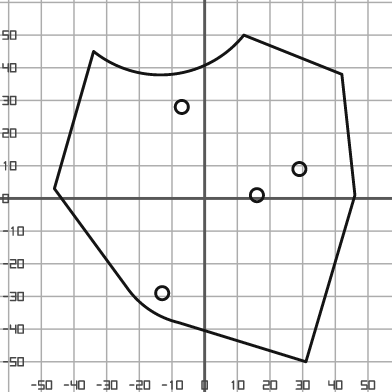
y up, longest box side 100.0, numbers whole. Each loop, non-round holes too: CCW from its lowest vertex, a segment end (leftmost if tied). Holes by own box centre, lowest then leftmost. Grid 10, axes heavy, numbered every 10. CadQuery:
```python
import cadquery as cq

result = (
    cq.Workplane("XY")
    .moveTo(31.0, -50.0)
    .lineTo(46.0, 1.0)
    .lineTo(42.0, 38.0)
    .lineTo(12.0, 50.0)
    .threePointArc((-10.0, 38.0), (-34.0, 45.0))
    .lineTo(-46.0, 3.0)
    .lineTo(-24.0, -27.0)
    .threePointArc((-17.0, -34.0), (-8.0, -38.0))
    .close()
    .moveTo(-13.0, -29.0)
    .circle(2.0)
    .moveTo(16.0, 1.0)
    .circle(2.0)
    .moveTo(29.0, 9.0)
    .circle(2.0)
    .moveTo(-7.0, 28.0)
    .circle(2.0)
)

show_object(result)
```